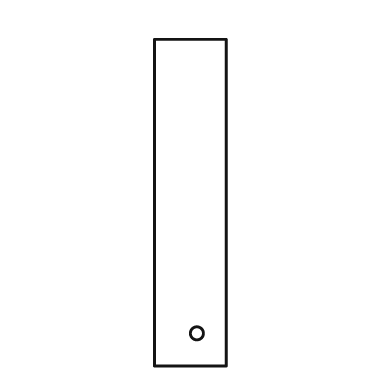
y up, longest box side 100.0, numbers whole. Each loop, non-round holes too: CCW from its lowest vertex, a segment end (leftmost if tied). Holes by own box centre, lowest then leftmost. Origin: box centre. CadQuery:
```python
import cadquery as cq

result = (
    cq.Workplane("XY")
    .moveTo(-11.0, -50.0)
    .lineTo(11.0, -50.0)
    .lineTo(11.0, 50.0)
    .lineTo(-11.0, 50.0)
    .close()
    .moveTo(2.0, -40.0)
    .circle(2.0)
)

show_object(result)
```